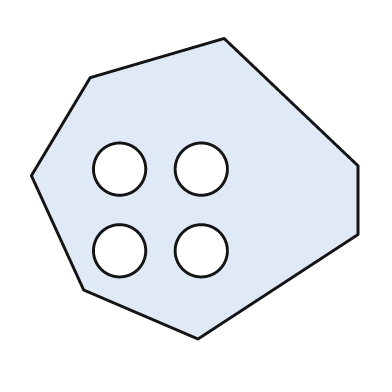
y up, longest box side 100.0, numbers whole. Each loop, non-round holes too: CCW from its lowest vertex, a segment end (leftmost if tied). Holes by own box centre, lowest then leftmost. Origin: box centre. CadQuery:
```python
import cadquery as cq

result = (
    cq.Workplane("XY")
    .moveTo(1.0, -46.0)
    .lineTo(50.0, -14.0)
    .lineTo(50.0, 7.0)
    .lineTo(9.0, 46.0)
    .lineTo(-32.0, 34.0)
    .lineTo(-50.0, 4.0)
    .lineTo(-34.0, -31.0)
    .close()
    .moveTo(-23.0, -19.0)
    .circle(8.0)
    .moveTo(2.0, -19.0)
    .circle(8.0)
    .moveTo(-23.0, 6.0)
    .circle(8.0)
    .moveTo(2.0, 6.0)
    .circle(8.0)
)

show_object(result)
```